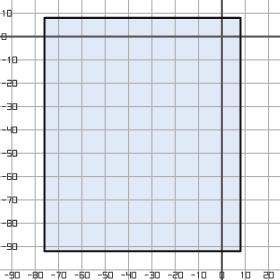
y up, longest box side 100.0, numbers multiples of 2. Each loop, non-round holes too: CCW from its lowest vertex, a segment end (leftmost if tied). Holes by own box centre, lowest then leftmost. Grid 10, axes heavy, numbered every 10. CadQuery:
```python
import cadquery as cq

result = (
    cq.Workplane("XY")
    .moveTo(-76.0, -92.0)
    .lineTo(8.0, -92.0)
    .lineTo(8.0, 8.0)
    .lineTo(-76.0, 8.0)
    .close()
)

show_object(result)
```